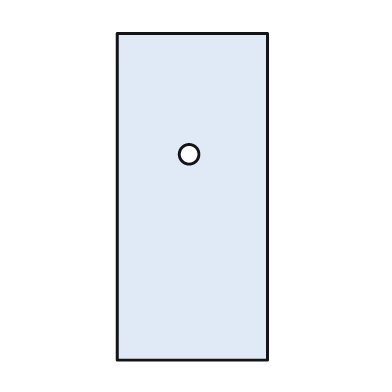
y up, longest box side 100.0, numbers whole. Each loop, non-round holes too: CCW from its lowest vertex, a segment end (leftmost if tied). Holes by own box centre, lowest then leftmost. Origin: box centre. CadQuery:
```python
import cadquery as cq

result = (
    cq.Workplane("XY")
    .moveTo(-23.0, -50.0)
    .lineTo(23.0, -50.0)
    .lineTo(23.0, 50.0)
    .lineTo(-23.0, 50.0)
    .close()
    .moveTo(-1.0, 13.0)
    .circle(3.0)
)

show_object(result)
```